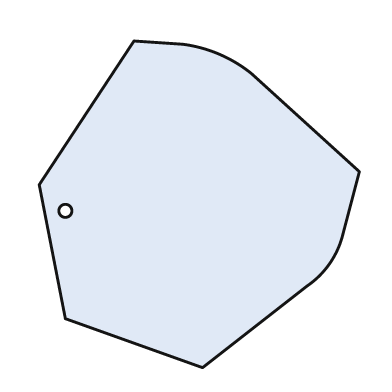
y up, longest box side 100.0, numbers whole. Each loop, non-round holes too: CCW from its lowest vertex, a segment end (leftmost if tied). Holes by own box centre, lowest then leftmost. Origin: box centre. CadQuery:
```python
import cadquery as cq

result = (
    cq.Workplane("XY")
    .moveTo(1.0, -50.0)
    .lineTo(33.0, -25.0)
    .threePointArc((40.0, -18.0), (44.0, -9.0))
    .lineTo(49.0, 10.0)
    .lineTo(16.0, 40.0)
    .threePointArc((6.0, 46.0), (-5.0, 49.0))
    .lineTo(-20.0, 50.0)
    .lineTo(-49.0, 6.0)
    .lineTo(-41.0, -35.0)
    .close()
    .moveTo(-41.0, -2.0)
    .circle(2.0)
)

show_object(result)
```